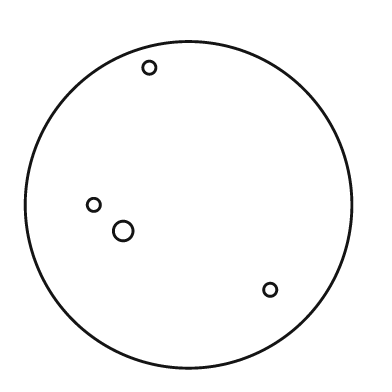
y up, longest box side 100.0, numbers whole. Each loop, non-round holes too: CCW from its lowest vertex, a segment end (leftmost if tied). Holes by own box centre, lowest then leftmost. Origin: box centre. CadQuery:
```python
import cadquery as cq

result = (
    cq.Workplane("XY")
    .moveTo(0.0, 0.0)
    .circle(50.0)
    .moveTo(25.0, -26.0)
    .circle(2.0)
    .moveTo(-20.0, -8.0)
    .circle(3.0)
    .moveTo(-29.0, 0.0)
    .circle(2.0)
    .moveTo(-12.0, 42.0)
    .circle(2.0)
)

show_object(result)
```